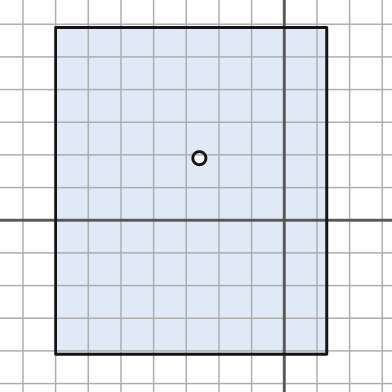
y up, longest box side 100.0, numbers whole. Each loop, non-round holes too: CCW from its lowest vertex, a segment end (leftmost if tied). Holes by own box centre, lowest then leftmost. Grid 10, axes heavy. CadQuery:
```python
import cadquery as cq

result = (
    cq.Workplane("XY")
    .moveTo(-70.0, -41.0)
    .lineTo(13.0, -41.0)
    .lineTo(13.0, 59.0)
    .lineTo(-70.0, 59.0)
    .close()
    .moveTo(-26.0, 19.0)
    .circle(2.0)
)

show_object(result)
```